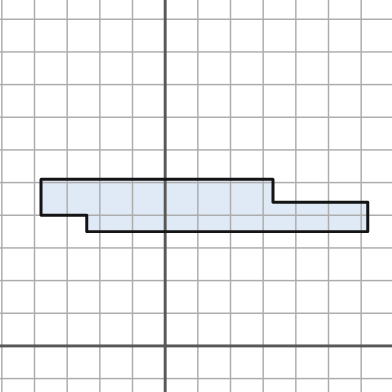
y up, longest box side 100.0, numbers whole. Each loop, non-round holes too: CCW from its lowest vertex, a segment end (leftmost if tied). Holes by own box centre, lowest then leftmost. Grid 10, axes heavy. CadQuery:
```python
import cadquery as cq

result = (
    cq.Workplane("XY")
    .moveTo(-24.0, 35.0)
    .lineTo(62.0, 35.0)
    .lineTo(62.0, 44.0)
    .lineTo(33.0, 44.0)
    .lineTo(33.0, 51.0)
    .lineTo(-38.0, 51.0)
    .lineTo(-38.0, 40.0)
    .lineTo(-24.0, 40.0)
    .close()
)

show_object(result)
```